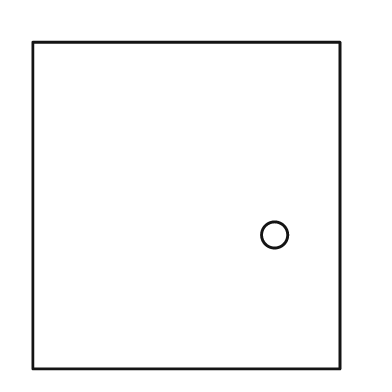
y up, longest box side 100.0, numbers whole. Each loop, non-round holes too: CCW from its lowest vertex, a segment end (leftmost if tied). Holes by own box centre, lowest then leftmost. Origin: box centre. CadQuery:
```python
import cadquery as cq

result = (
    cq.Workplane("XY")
    .moveTo(-47.0, -50.0)
    .lineTo(47.0, -50.0)
    .lineTo(47.0, 50.0)
    .lineTo(-47.0, 50.0)
    .close()
    .moveTo(27.0, -9.0)
    .circle(4.0)
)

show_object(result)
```